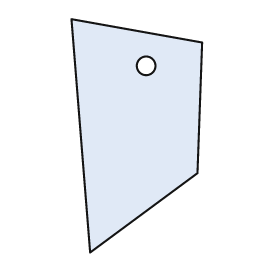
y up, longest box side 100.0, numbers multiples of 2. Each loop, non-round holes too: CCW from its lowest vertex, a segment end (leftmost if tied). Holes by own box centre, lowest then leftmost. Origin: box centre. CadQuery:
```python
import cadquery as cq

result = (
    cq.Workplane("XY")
    .moveTo(-20.0, -50.0)
    .lineTo(26.0, -16.0)
    .lineTo(28.0, 40.0)
    .lineTo(-28.0, 50.0)
    .close()
    .moveTo(4.0, 30.0)
    .circle(4.0)
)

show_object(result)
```